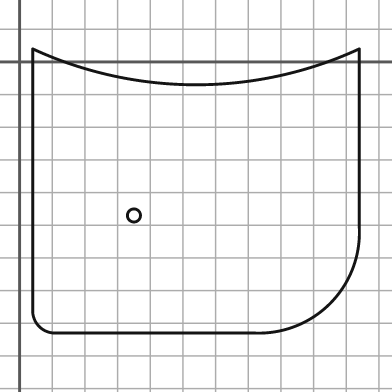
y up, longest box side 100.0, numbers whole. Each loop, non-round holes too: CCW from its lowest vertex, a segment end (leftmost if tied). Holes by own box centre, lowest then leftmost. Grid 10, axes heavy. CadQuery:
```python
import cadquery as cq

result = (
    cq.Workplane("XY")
    .moveTo(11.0, -83.0)
    .lineTo(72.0, -83.0)
    .threePointArc((95.0, -74.0), (104.0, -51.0))
    .lineTo(104.0, 4.0)
    .threePointArc((54.0, -7.0), (4.0, 4.0))
    .lineTo(4.0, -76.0)
    .threePointArc((6.0, -81.0), (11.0, -83.0))
    .close()
    .moveTo(35.0, -47.0)
    .circle(2.0)
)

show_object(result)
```